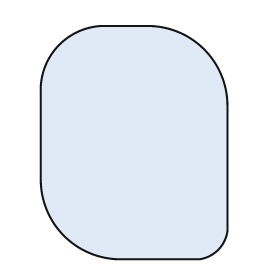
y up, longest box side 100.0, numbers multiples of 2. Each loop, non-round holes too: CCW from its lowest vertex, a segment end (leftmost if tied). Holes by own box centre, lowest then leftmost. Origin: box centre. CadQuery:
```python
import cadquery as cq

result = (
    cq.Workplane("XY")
    .moveTo(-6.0, -50.0)
    .lineTo(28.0, -50.0)
    .threePointArc((36.0, -46.0), (40.0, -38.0))
    .lineTo(40.0, 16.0)
    .threePointArc((30.0, 40.0), (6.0, 50.0))
    .lineTo(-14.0, 50.0)
    .threePointArc((-32.0, 42.0), (-40.0, 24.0))
    .lineTo(-40.0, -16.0)
    .threePointArc((-30.0, -40.0), (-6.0, -50.0))
    .close()
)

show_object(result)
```